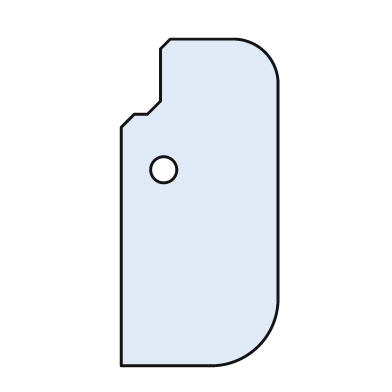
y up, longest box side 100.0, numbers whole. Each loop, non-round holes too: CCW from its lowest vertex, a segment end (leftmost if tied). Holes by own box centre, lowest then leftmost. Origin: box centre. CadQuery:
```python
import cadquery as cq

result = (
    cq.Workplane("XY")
    .moveTo(-24.0, -50.0)
    .lineTo(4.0, -50.0)
    .threePointArc((18.0, -44.0), (24.0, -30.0))
    .lineTo(24.0, 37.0)
    .threePointArc((20.0, 46.0), (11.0, 50.0))
    .lineTo(-9.0, 50.0)
    .lineTo(-12.0, 47.0)
    .lineTo(-12.0, 31.0)
    .lineTo(-16.0, 27.0)
    .lineTo(-20.0, 27.0)
    .lineTo(-24.0, 23.0)
    .close()
    .moveTo(-11.0, 10.0)
    .circle(4.0)
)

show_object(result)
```